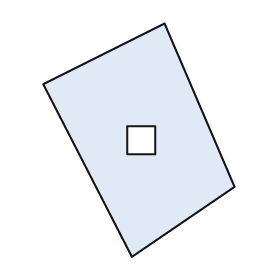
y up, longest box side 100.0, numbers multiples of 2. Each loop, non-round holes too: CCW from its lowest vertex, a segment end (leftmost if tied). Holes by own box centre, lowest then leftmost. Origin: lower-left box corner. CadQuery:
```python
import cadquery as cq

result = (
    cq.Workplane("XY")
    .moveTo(38.0, 0.0)
    .lineTo(82.0, 30.0)
    .lineTo(52.0, 100.0)
    .lineTo(0.0, 74.0)
    .close()
    .moveTo(36.0, 44.0)
    .lineTo(48.0, 44.0)
    .lineTo(48.0, 56.0)
    .lineTo(36.0, 56.0)
    .close()
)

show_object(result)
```